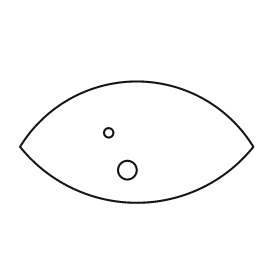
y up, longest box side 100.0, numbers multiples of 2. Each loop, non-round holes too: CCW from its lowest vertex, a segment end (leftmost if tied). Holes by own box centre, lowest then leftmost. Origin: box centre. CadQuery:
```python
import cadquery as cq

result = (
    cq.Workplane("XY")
    .moveTo(-50.0, -2.0)
    .threePointArc((0.0, -26.0), (50.0, -2.0))
    .threePointArc((0.0, 26.0), (-50.0, -2.0))
    .close()
    .moveTo(-4.0, -12.0)
    .circle(4.0)
    .moveTo(-12.0, 4.0)
    .circle(2.0)
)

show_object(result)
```